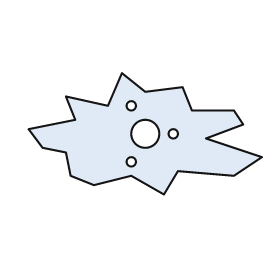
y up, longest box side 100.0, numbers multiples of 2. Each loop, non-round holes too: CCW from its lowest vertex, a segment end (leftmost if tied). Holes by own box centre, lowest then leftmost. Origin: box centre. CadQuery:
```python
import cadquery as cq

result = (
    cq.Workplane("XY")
    .moveTo(8.0, -26.0)
    .lineTo(14.0, -16.0)
    .lineTo(38.0, -18.0)
    .lineTo(50.0, -10.0)
    .lineTo(26.0, -2.0)
    .lineTo(42.0, 4.0)
    .lineTo(38.0, 10.0)
    .lineTo(20.0, 10.0)
    .lineTo(16.0, 20.0)
    .lineTo(0.0, 18.0)
    .lineTo(-10.0, 26.0)
    .lineTo(-16.0, 12.0)
    .lineTo(-34.0, 16.0)
    .lineTo(-30.0, 6.0)
    .lineTo(-50.0, 2.0)
    .lineTo(-44.0, -6.0)
    .lineTo(-34.0, -8.0)
    .lineTo(-32.0, -18.0)
    .lineTo(-22.0, -22.0)
    .lineTo(-6.0, -18.0)
    .close()
    .moveTo(-6.0, -12.0)
    .circle(2.0)
    .moveTo(0.0, 0.0)
    .circle(6.0)
    .moveTo(12.0, 0.0)
    .circle(2.0)
    .moveTo(-6.0, 12.0)
    .circle(2.0)
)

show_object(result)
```